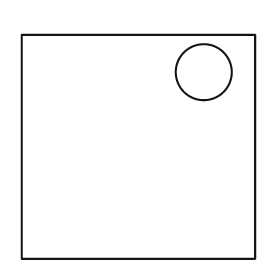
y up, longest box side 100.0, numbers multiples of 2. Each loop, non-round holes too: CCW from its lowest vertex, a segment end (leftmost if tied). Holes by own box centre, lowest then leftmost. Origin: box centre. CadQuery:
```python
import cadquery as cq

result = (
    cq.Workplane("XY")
    .moveTo(-50.0, -48.0)
    .lineTo(50.0, -48.0)
    .lineTo(50.0, 48.0)
    .lineTo(-50.0, 48.0)
    .close()
    .moveTo(28.0, 32.0)
    .circle(12.0)
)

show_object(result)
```